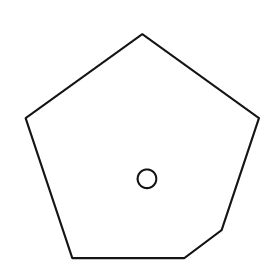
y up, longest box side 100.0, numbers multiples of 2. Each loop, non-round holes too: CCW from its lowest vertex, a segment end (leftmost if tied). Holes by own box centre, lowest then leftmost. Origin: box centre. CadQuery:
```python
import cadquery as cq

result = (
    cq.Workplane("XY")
    .moveTo(-30.0, -48.0)
    .lineTo(18.0, -48.0)
    .lineTo(34.0, -36.0)
    .lineTo(50.0, 12.0)
    .lineTo(0.0, 48.0)
    .lineTo(-50.0, 12.0)
    .close()
    .moveTo(2.0, -14.0)
    .circle(4.0)
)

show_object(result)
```